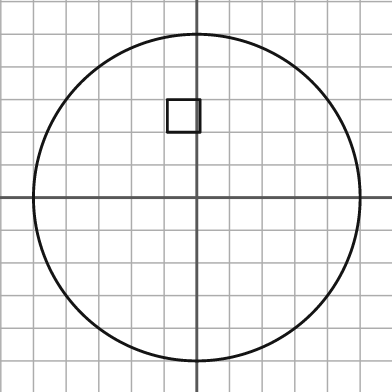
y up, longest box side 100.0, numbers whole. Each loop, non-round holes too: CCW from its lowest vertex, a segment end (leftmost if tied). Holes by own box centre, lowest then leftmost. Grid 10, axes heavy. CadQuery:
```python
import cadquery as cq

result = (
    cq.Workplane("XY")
    .moveTo(0.0, 0.0)
    .circle(50.0)
    .moveTo(-9.0, 20.0)
    .lineTo(1.0, 20.0)
    .lineTo(1.0, 30.0)
    .lineTo(-9.0, 30.0)
    .close()
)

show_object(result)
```